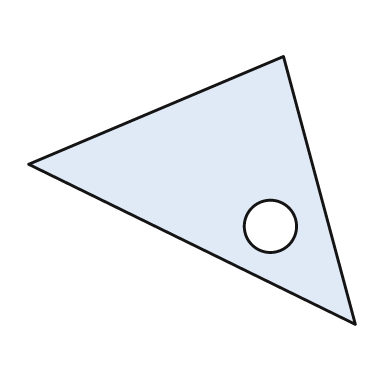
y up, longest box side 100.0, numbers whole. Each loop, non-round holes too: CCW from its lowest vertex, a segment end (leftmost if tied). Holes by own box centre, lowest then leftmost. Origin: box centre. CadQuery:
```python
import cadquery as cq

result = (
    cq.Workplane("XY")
    .moveTo(50.0, -41.0)
    .lineTo(28.0, 41.0)
    .lineTo(-50.0, 8.0)
    .close()
    .moveTo(24.0, -11.0)
    .circle(8.0)
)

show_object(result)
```